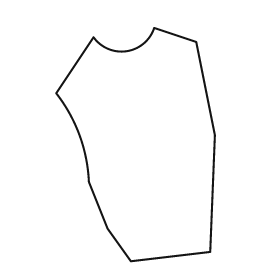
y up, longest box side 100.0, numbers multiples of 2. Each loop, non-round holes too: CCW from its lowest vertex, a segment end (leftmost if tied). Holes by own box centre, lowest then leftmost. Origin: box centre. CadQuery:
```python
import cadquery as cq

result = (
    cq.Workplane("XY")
    .moveTo(-2.0, -50.0)
    .lineTo(32.0, -46.0)
    .lineTo(34.0, 4.0)
    .lineTo(26.0, 44.0)
    .lineTo(8.0, 50.0)
    .threePointArc((-4.0, 40.0), (-18.0, 46.0))
    .lineTo(-34.0, 22.0)
    .threePointArc((-24.0, 4.0), (-20.0, -16.0))
    .lineTo(-12.0, -36.0)
    .close()
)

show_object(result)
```